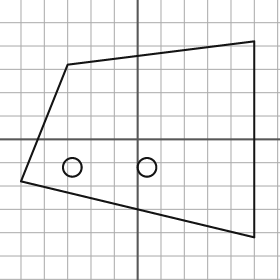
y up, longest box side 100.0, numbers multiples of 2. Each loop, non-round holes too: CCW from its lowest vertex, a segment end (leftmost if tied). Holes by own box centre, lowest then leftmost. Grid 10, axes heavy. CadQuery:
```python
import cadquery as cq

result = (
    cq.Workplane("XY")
    .moveTo(50.0, -42.0)
    .lineTo(50.0, 42.0)
    .lineTo(-30.0, 32.0)
    .lineTo(-50.0, -18.0)
    .close()
    .moveTo(-28.0, -12.0)
    .circle(4.0)
    .moveTo(4.0, -12.0)
    .circle(4.0)
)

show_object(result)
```